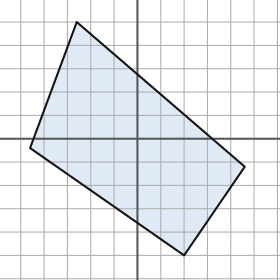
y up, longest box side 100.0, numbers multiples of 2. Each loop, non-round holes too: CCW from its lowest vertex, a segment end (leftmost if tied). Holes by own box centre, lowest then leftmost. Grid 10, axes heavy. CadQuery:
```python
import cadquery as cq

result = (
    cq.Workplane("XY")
    .moveTo(20.0, -50.0)
    .lineTo(46.0, -12.0)
    .lineTo(-26.0, 50.0)
    .lineTo(-46.0, -4.0)
    .close()
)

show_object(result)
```